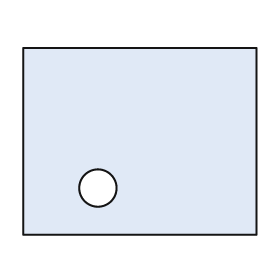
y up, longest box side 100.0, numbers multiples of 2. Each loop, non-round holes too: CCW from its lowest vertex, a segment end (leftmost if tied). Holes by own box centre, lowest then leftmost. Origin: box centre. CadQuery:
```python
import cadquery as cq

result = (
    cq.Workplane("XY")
    .moveTo(-50.0, -40.0)
    .lineTo(50.0, -40.0)
    .lineTo(50.0, 40.0)
    .lineTo(-50.0, 40.0)
    .close()
    .moveTo(-18.0, -20.0)
    .circle(8.0)
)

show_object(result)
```